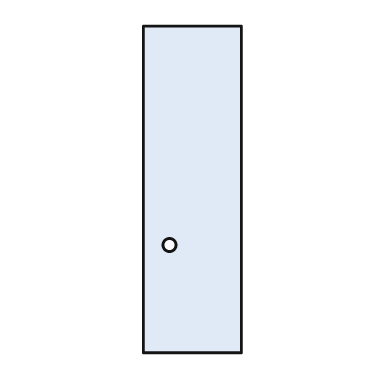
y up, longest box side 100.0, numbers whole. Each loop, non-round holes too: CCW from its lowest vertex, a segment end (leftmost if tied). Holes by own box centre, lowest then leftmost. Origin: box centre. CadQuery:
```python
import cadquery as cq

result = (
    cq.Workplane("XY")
    .moveTo(-15.0, -50.0)
    .lineTo(15.0, -50.0)
    .lineTo(15.0, 50.0)
    .lineTo(-15.0, 50.0)
    .close()
    .moveTo(-7.0, -17.0)
    .circle(2.0)
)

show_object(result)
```